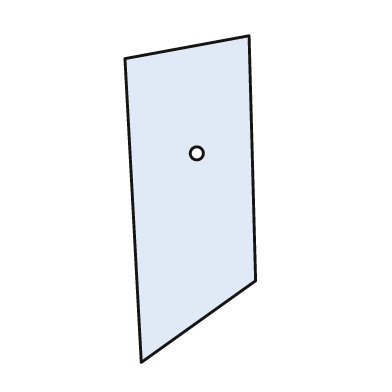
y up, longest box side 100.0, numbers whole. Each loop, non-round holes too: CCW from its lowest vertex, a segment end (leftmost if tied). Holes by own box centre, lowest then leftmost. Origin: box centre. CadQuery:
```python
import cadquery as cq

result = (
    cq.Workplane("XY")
    .moveTo(-15.0, -50.0)
    .lineTo(20.0, -25.0)
    .lineTo(18.0, 50.0)
    .lineTo(-20.0, 43.0)
    .close()
    .moveTo(2.0, 14.0)
    .circle(2.0)
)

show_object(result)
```